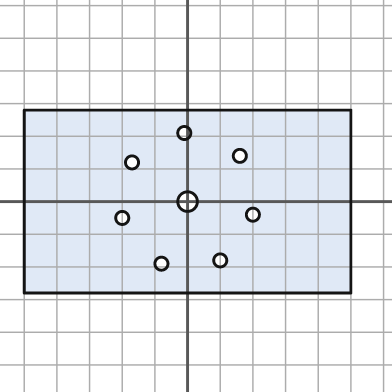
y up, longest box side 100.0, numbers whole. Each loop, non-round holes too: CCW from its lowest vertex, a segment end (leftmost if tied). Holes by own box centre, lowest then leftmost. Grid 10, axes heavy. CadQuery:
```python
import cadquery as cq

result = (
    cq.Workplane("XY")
    .moveTo(-50.0, -28.0)
    .lineTo(50.0, -28.0)
    .lineTo(50.0, 28.0)
    .lineTo(-50.0, 28.0)
    .close()
    .moveTo(-8.0, -19.0)
    .circle(2.0)
    .moveTo(10.0, -18.0)
    .circle(2.0)
    .moveTo(-20.0, -5.0)
    .circle(2.0)
    .moveTo(20.0, -4.0)
    .circle(2.0)
    .moveTo(0.0, 0.0)
    .circle(3.0)
    .moveTo(-17.0, 12.0)
    .circle(2.0)
    .moveTo(16.0, 14.0)
    .circle(2.0)
    .moveTo(-1.0, 21.0)
    .circle(2.0)
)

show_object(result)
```